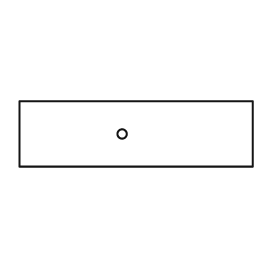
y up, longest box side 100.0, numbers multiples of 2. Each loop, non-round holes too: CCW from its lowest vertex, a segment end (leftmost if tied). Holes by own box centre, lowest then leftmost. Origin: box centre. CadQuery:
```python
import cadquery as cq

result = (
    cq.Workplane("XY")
    .moveTo(-50.0, -14.0)
    .lineTo(50.0, -14.0)
    .lineTo(50.0, 14.0)
    .lineTo(-50.0, 14.0)
    .close()
    .moveTo(-6.0, 0.0)
    .circle(2.0)
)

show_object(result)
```